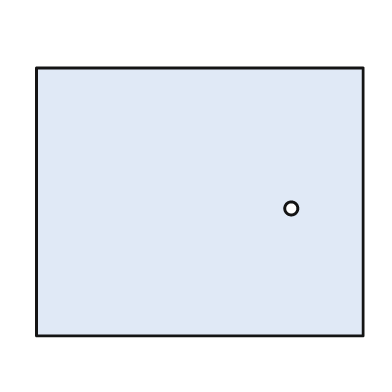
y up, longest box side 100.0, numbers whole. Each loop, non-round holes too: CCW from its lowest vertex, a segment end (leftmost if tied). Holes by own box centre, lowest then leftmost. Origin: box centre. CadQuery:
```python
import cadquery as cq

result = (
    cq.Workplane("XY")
    .moveTo(-50.0, -41.0)
    .lineTo(50.0, -41.0)
    .lineTo(50.0, 41.0)
    .lineTo(-50.0, 41.0)
    .close()
    .moveTo(28.0, -2.0)
    .circle(2.0)
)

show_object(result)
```